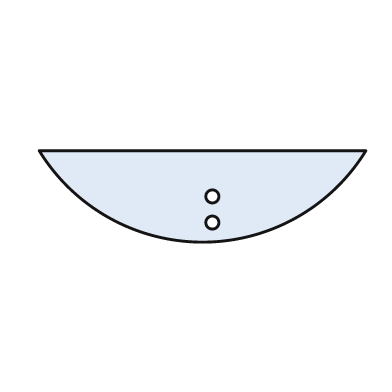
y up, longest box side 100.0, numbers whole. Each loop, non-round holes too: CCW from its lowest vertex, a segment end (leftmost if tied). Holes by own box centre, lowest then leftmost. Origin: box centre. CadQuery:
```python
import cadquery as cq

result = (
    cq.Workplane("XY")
    .moveTo(-50.0, 14.0)
    .threePointArc((0.0, -14.0), (50.0, 14.0))
    .close()
    .moveTo(3.0, -8.0)
    .circle(2.0)
    .moveTo(3.0, 0.0)
    .circle(2.0)
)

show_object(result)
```